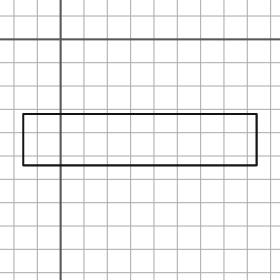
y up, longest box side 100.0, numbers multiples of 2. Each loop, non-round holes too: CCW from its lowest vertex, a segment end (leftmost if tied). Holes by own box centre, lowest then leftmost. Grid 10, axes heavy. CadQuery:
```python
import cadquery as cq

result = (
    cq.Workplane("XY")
    .moveTo(-16.0, -54.0)
    .lineTo(84.0, -54.0)
    .lineTo(84.0, -32.0)
    .lineTo(-16.0, -32.0)
    .close()
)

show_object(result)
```